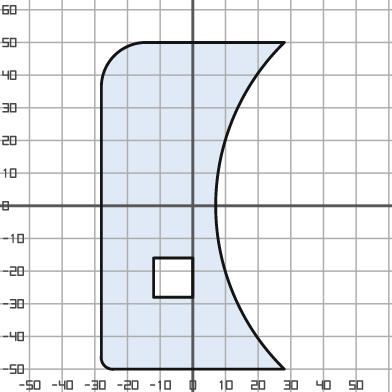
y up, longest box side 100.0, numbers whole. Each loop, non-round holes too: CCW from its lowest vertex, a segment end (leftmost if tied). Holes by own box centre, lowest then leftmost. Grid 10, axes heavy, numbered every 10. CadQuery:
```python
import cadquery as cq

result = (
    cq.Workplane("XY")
    .moveTo(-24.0, -50.0)
    .lineTo(28.0, -50.0)
    .threePointArc((7.0, 0.0), (28.0, 50.0))
    .lineTo(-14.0, 50.0)
    .threePointArc((-24.0, 46.0), (-28.0, 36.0))
    .lineTo(-28.0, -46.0)
    .threePointArc((-27.0, -49.0), (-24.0, -50.0))
    .close()
    .moveTo(-12.0, -28.0)
    .lineTo(0.0, -28.0)
    .lineTo(0.0, -16.0)
    .lineTo(-12.0, -16.0)
    .close()
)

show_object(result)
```